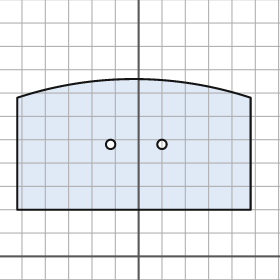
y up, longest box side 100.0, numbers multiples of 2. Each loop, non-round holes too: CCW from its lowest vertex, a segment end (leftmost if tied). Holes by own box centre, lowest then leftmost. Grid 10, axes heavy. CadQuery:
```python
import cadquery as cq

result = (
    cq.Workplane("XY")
    .moveTo(-52.0, 20.0)
    .lineTo(48.0, 20.0)
    .lineTo(48.0, 68.0)
    .threePointArc((-2.0, 76.0), (-52.0, 68.0))
    .close()
    .moveTo(-12.0, 48.0)
    .circle(2.0)
    .moveTo(10.0, 48.0)
    .circle(2.0)
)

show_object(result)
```